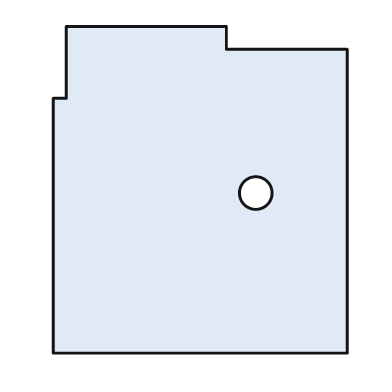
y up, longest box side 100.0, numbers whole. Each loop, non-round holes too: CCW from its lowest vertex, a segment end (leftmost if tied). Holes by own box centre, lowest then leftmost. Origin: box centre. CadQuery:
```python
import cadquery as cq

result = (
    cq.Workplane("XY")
    .moveTo(-45.0, -50.0)
    .lineTo(45.0, -50.0)
    .lineTo(45.0, 43.0)
    .lineTo(8.0, 43.0)
    .lineTo(8.0, 50.0)
    .lineTo(-41.0, 50.0)
    .lineTo(-41.0, 28.0)
    .lineTo(-45.0, 28.0)
    .close()
    .moveTo(17.0, -1.0)
    .circle(5.0)
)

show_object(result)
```